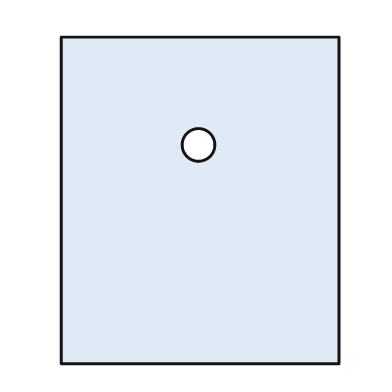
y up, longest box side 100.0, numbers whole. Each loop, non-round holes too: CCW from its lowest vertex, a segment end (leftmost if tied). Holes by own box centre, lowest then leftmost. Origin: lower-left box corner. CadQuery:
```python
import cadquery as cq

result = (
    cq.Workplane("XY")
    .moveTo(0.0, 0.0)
    .lineTo(85.0, 0.0)
    .lineTo(85.0, 100.0)
    .lineTo(0.0, 100.0)
    .close()
    .moveTo(42.0, 67.0)
    .circle(5.0)
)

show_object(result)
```